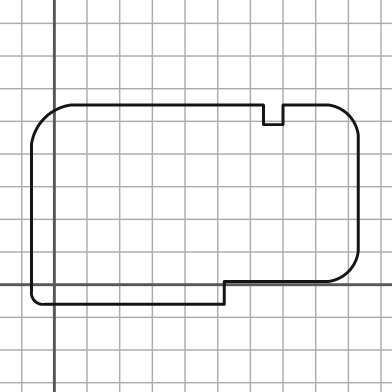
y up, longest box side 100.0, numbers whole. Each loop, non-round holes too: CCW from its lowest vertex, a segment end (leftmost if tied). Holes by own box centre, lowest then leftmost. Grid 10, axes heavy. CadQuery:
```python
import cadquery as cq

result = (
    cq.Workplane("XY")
    .moveTo(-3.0, -6.0)
    .lineTo(52.0, -6.0)
    .lineTo(52.0, 1.0)
    .lineTo(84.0, 1.0)
    .threePointArc((90.0, 4.0), (93.0, 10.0))
    .lineTo(93.0, 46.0)
    .threePointArc((90.0, 52.0), (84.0, 55.0))
    .lineTo(70.0, 55.0)
    .lineTo(70.0, 49.0)
    .lineTo(64.0, 49.0)
    .lineTo(64.0, 55.0)
    .lineTo(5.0, 55.0)
    .threePointArc((-3.0, 51.0), (-7.0, 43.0))
    .lineTo(-7.0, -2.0)
    .threePointArc((-6.0, -5.0), (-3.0, -6.0))
    .close()
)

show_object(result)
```